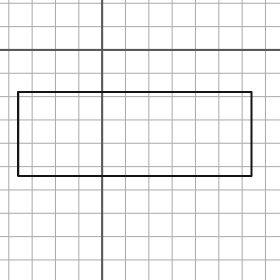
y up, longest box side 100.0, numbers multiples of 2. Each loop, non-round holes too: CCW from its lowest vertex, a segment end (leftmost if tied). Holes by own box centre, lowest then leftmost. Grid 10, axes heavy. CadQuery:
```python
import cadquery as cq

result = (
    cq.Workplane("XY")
    .moveTo(-36.0, -54.0)
    .lineTo(64.0, -54.0)
    .lineTo(64.0, -18.0)
    .lineTo(-36.0, -18.0)
    .close()
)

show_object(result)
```